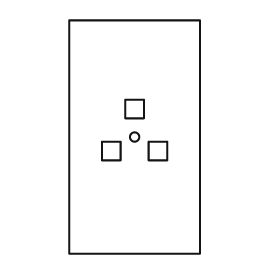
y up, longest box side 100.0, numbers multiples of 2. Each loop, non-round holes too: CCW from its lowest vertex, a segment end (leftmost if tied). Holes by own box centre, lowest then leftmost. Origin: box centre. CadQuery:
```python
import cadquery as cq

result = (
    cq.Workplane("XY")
    .moveTo(-28.0, -50.0)
    .lineTo(28.0, -50.0)
    .lineTo(28.0, 50.0)
    .lineTo(-28.0, 50.0)
    .close()
    .moveTo(-14.0, -10.0)
    .lineTo(-6.0, -10.0)
    .lineTo(-6.0, -2.0)
    .lineTo(-14.0, -2.0)
    .close()
    .moveTo(6.0, -10.0)
    .lineTo(14.0, -10.0)
    .lineTo(14.0, -2.0)
    .lineTo(6.0, -2.0)
    .close()
    .moveTo(0.0, 0.0)
    .circle(2.0)
    .moveTo(-4.0, 8.0)
    .lineTo(4.0, 8.0)
    .lineTo(4.0, 16.0)
    .lineTo(-4.0, 16.0)
    .close()
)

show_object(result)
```